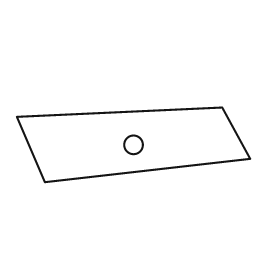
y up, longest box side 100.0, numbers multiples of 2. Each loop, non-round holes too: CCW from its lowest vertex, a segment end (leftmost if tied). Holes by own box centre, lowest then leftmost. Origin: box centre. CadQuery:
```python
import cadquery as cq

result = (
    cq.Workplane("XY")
    .moveTo(-38.0, -16.0)
    .lineTo(50.0, -6.0)
    .lineTo(38.0, 16.0)
    .lineTo(-50.0, 12.0)
    .close()
    .moveTo(0.0, 0.0)
    .circle(4.0)
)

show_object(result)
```